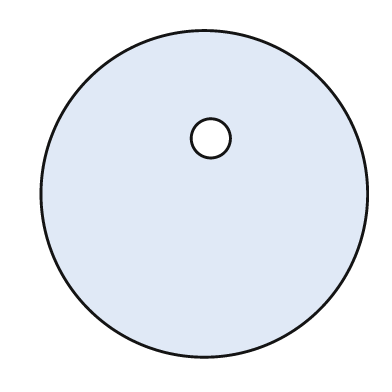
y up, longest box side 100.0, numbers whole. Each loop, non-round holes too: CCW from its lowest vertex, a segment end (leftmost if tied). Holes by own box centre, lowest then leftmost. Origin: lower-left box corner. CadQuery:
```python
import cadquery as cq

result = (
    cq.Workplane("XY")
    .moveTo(50.0, 50.0)
    .circle(50.0)
    .moveTo(52.0, 67.0)
    .circle(6.0)
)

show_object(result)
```